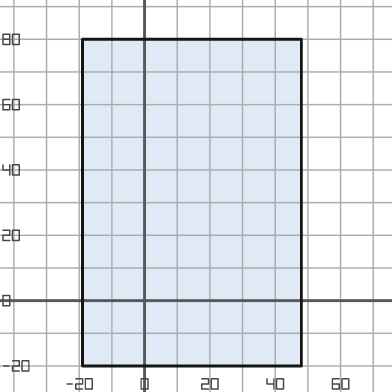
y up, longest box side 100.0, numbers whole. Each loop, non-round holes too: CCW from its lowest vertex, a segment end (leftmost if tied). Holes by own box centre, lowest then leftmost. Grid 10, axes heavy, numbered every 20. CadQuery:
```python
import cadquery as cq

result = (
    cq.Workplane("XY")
    .moveTo(-19.0, -20.0)
    .lineTo(48.0, -20.0)
    .lineTo(48.0, 80.0)
    .lineTo(-19.0, 80.0)
    .close()
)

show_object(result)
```